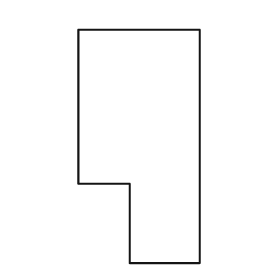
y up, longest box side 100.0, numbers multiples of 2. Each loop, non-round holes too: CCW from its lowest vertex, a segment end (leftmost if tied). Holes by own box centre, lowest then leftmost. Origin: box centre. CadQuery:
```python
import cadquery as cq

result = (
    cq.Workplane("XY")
    .moveTo(-4.0, -50.0)
    .lineTo(26.0, -50.0)
    .lineTo(26.0, 50.0)
    .lineTo(-26.0, 50.0)
    .lineTo(-26.0, -16.0)
    .lineTo(-4.0, -16.0)
    .close()
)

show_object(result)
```